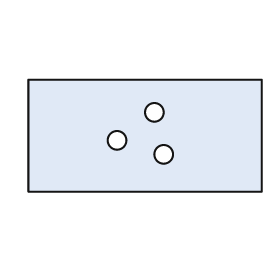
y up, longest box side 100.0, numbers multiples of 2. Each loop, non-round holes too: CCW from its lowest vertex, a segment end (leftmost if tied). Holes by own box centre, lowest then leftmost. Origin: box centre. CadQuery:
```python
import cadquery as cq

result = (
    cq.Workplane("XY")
    .moveTo(-50.0, -24.0)
    .lineTo(50.0, -24.0)
    .lineTo(50.0, 24.0)
    .lineTo(-50.0, 24.0)
    .close()
    .moveTo(8.0, -8.0)
    .circle(4.0)
    .moveTo(-12.0, -2.0)
    .circle(4.0)
    .moveTo(4.0, 10.0)
    .circle(4.0)
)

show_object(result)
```